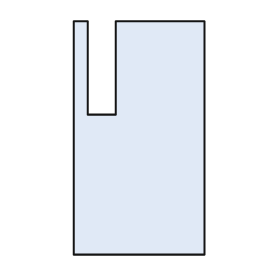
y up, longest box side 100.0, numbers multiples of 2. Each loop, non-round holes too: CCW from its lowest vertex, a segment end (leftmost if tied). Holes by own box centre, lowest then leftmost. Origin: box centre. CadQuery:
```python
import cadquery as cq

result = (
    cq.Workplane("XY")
    .moveTo(-28.0, -50.0)
    .lineTo(28.0, -50.0)
    .lineTo(28.0, 50.0)
    .lineTo(-10.0, 50.0)
    .lineTo(-10.0, 10.0)
    .lineTo(-22.0, 10.0)
    .lineTo(-22.0, 50.0)
    .lineTo(-28.0, 50.0)
    .close()
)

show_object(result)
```